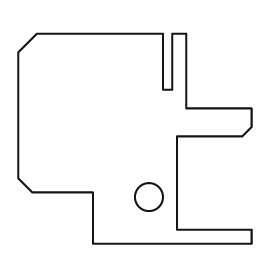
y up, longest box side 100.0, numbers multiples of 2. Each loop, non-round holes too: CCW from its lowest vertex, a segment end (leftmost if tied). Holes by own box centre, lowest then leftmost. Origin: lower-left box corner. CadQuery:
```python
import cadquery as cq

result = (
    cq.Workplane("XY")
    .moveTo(32.0, 0.0)
    .lineTo(100.0, 0.0)
    .lineTo(100.0, 6.0)
    .lineTo(68.0, 6.0)
    .lineTo(68.0, 46.0)
    .lineTo(96.0, 46.0)
    .lineTo(100.0, 50.0)
    .lineTo(100.0, 58.0)
    .lineTo(72.0, 58.0)
    .lineTo(72.0, 90.0)
    .lineTo(66.0, 90.0)
    .lineTo(66.0, 66.0)
    .lineTo(62.0, 66.0)
    .lineTo(62.0, 90.0)
    .lineTo(8.0, 90.0)
    .lineTo(0.0, 82.0)
    .lineTo(0.0, 28.0)
    .lineTo(6.0, 22.0)
    .lineTo(32.0, 22.0)
    .close()
    .moveTo(56.0, 20.0)
    .circle(6.0)
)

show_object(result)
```